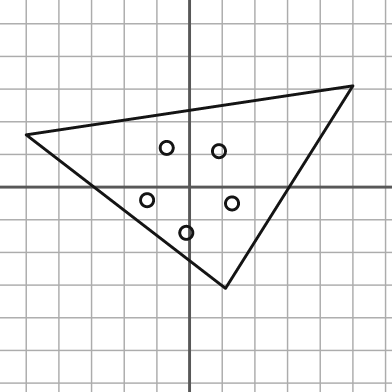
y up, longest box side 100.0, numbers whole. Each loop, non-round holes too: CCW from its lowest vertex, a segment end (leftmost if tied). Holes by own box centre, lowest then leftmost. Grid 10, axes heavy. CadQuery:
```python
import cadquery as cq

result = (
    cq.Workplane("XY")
    .moveTo(11.0, -31.0)
    .lineTo(50.0, 31.0)
    .lineTo(-50.0, 16.0)
    .close()
    .moveTo(-1.0, -14.0)
    .circle(2.0)
    .moveTo(13.0, -5.0)
    .circle(2.0)
    .moveTo(-13.0, -4.0)
    .circle(2.0)
    .moveTo(9.0, 11.0)
    .circle(2.0)
    .moveTo(-7.0, 12.0)
    .circle(2.0)
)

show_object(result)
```